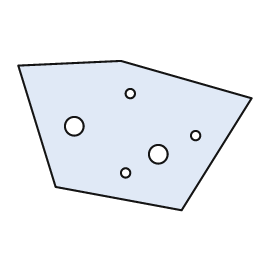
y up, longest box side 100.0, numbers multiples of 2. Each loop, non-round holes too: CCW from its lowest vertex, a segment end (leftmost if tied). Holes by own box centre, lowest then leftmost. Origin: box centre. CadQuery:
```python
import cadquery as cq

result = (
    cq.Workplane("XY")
    .moveTo(20.0, -32.0)
    .lineTo(50.0, 16.0)
    .lineTo(-6.0, 32.0)
    .lineTo(-50.0, 30.0)
    .lineTo(-34.0, -22.0)
    .close()
    .moveTo(-4.0, -16.0)
    .circle(2.0)
    .moveTo(10.0, -8.0)
    .circle(4.0)
    .moveTo(26.0, 0.0)
    .circle(2.0)
    .moveTo(-26.0, 4.0)
    .circle(4.0)
    .moveTo(-2.0, 18.0)
    .circle(2.0)
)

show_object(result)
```